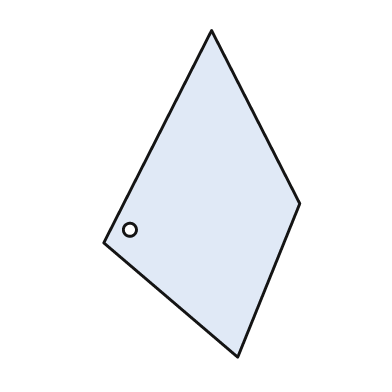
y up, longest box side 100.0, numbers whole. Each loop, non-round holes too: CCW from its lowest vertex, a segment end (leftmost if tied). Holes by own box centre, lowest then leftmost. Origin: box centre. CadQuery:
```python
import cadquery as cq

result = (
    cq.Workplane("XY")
    .moveTo(11.0, -50.0)
    .lineTo(30.0, -3.0)
    .lineTo(3.0, 50.0)
    .lineTo(-30.0, -15.0)
    .close()
    .moveTo(-22.0, -11.0)
    .circle(2.0)
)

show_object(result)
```